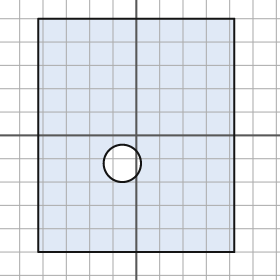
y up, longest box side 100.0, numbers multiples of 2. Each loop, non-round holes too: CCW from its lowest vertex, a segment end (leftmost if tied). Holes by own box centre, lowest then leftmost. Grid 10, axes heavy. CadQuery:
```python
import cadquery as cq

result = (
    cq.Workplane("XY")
    .moveTo(-42.0, -50.0)
    .lineTo(42.0, -50.0)
    .lineTo(42.0, 50.0)
    .lineTo(-42.0, 50.0)
    .close()
    .moveTo(-6.0, -12.0)
    .circle(8.0)
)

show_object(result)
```